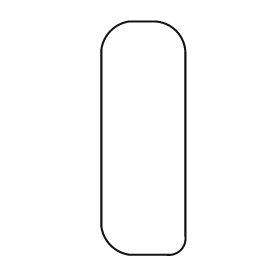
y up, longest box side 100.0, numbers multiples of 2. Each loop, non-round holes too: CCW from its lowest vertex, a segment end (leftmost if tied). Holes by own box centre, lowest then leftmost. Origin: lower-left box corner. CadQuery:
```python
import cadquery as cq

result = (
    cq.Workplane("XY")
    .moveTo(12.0, 0.0)
    .lineTo(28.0, 0.0)
    .threePointArc((34.0, 2.0), (36.0, 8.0))
    .lineTo(36.0, 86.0)
    .threePointArc((32.0, 96.0), (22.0, 100.0))
    .lineTo(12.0, 100.0)
    .threePointArc((4.0, 96.0), (0.0, 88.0))
    .lineTo(0.0, 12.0)
    .threePointArc((4.0, 4.0), (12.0, 0.0))
    .close()
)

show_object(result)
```